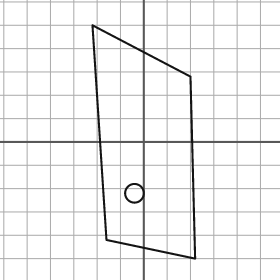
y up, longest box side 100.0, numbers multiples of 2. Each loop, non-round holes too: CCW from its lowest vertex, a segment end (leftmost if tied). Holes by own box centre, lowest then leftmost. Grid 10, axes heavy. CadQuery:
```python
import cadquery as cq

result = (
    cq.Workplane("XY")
    .moveTo(22.0, -50.0)
    .lineTo(20.0, 28.0)
    .lineTo(-22.0, 50.0)
    .lineTo(-16.0, -42.0)
    .close()
    .moveTo(-4.0, -22.0)
    .circle(4.0)
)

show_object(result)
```